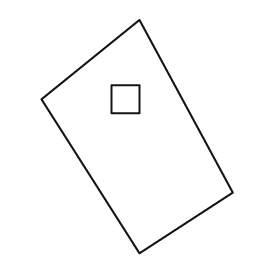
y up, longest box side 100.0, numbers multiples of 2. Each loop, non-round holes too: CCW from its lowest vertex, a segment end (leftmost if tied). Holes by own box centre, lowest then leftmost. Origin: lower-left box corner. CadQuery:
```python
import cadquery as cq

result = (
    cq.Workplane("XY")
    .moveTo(42.0, 0.0)
    .lineTo(82.0, 26.0)
    .lineTo(42.0, 100.0)
    .lineTo(0.0, 66.0)
    .close()
    .moveTo(30.0, 60.0)
    .lineTo(42.0, 60.0)
    .lineTo(42.0, 72.0)
    .lineTo(30.0, 72.0)
    .close()
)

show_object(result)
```